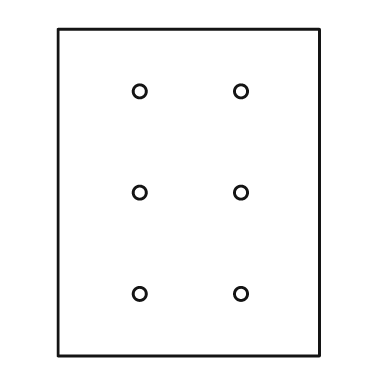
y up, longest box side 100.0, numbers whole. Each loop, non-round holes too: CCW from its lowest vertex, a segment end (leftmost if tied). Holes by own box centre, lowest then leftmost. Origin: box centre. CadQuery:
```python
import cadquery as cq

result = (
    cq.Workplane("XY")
    .moveTo(-40.0, -50.0)
    .lineTo(40.0, -50.0)
    .lineTo(40.0, 50.0)
    .lineTo(-40.0, 50.0)
    .close()
    .moveTo(-15.0, -31.0)
    .circle(2.0)
    .moveTo(16.0, -31.0)
    .circle(2.0)
    .moveTo(-15.0, 0.0)
    .circle(2.0)
    .moveTo(16.0, 0.0)
    .circle(2.0)
    .moveTo(-15.0, 31.0)
    .circle(2.0)
    .moveTo(16.0, 31.0)
    .circle(2.0)
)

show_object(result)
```